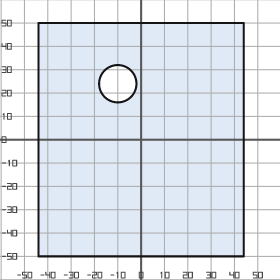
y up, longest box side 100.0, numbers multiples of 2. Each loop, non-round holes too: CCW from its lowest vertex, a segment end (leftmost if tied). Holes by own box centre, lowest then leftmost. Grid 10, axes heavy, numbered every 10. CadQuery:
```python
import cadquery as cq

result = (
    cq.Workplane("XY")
    .moveTo(-44.0, -50.0)
    .lineTo(44.0, -50.0)
    .lineTo(44.0, 50.0)
    .lineTo(-44.0, 50.0)
    .close()
    .moveTo(-10.0, 24.0)
    .circle(8.0)
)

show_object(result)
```